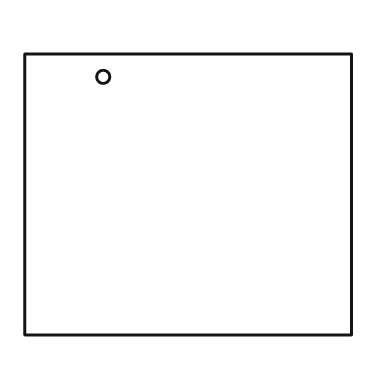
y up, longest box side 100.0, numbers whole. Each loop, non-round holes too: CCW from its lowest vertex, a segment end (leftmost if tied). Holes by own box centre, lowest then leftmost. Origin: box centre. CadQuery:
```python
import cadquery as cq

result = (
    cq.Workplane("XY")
    .moveTo(-50.0, -43.0)
    .lineTo(50.0, -43.0)
    .lineTo(50.0, 43.0)
    .lineTo(-50.0, 43.0)
    .close()
    .moveTo(-26.0, 36.0)
    .circle(2.0)
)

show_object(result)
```